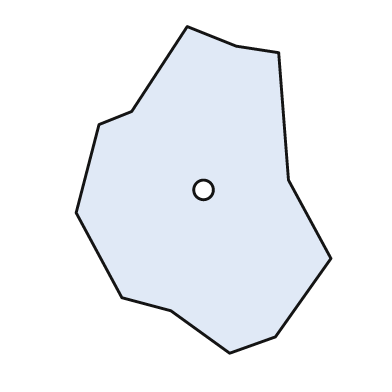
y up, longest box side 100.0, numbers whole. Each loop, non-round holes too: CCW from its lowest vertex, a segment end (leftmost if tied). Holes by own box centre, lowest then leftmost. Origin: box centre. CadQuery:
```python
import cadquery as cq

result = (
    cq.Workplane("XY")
    .moveTo(8.0, -50.0)
    .lineTo(22.0, -45.0)
    .lineTo(39.0, -21.0)
    .lineTo(26.0, 3.0)
    .lineTo(23.0, 42.0)
    .lineTo(10.0, 44.0)
    .lineTo(-5.0, 50.0)
    .lineTo(-22.0, 24.0)
    .lineTo(-32.0, 20.0)
    .lineTo(-39.0, -7.0)
    .lineTo(-25.0, -33.0)
    .lineTo(-10.0, -37.0)
    .close()
    .moveTo(0.0, 0.0)
    .circle(3.0)
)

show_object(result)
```